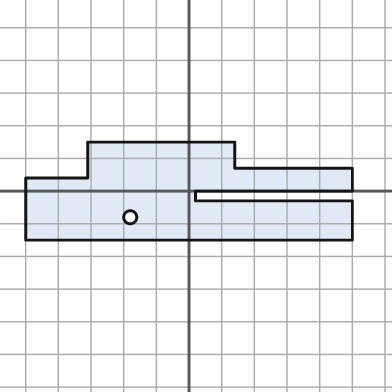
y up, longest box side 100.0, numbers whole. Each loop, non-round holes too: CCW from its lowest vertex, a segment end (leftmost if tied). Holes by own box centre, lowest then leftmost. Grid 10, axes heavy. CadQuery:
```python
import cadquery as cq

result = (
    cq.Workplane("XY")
    .moveTo(-50.0, -15.0)
    .lineTo(50.0, -15.0)
    .lineTo(50.0, -3.0)
    .lineTo(2.0, -3.0)
    .lineTo(2.0, 0.0)
    .lineTo(50.0, 0.0)
    .lineTo(50.0, 7.0)
    .lineTo(14.0, 7.0)
    .lineTo(14.0, 15.0)
    .lineTo(-31.0, 15.0)
    .lineTo(-31.0, 4.0)
    .lineTo(-50.0, 4.0)
    .close()
    .moveTo(-18.0, -8.0)
    .circle(2.0)
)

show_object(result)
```